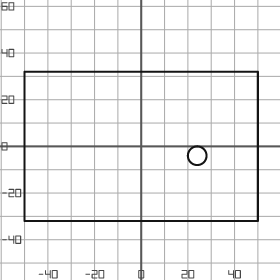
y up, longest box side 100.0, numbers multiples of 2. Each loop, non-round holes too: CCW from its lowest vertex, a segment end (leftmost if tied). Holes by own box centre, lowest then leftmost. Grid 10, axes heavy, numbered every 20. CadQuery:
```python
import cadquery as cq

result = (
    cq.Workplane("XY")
    .moveTo(-50.0, -32.0)
    .lineTo(50.0, -32.0)
    .lineTo(50.0, 32.0)
    .lineTo(-50.0, 32.0)
    .close()
    .moveTo(24.0, -4.0)
    .circle(4.0)
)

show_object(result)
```